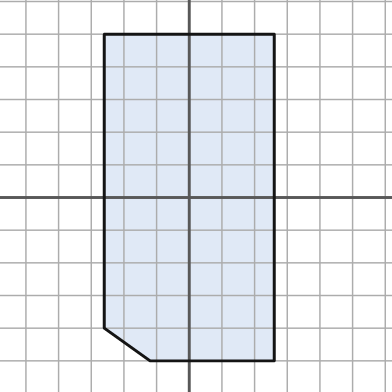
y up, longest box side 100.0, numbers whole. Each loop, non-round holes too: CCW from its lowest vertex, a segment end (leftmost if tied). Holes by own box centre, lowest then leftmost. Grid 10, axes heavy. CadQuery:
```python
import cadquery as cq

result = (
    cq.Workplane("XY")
    .moveTo(-12.0, -50.0)
    .lineTo(26.0, -50.0)
    .lineTo(26.0, 50.0)
    .lineTo(-26.0, 50.0)
    .lineTo(-26.0, -40.0)
    .close()
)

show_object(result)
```